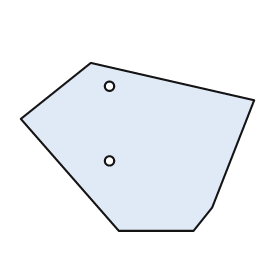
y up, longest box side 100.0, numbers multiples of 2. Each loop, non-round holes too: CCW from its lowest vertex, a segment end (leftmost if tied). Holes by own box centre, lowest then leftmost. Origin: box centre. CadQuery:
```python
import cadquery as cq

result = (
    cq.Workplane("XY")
    .moveTo(-8.0, -36.0)
    .lineTo(24.0, -36.0)
    .lineTo(32.0, -26.0)
    .lineTo(50.0, 20.0)
    .lineTo(-20.0, 36.0)
    .lineTo(-50.0, 12.0)
    .close()
    .moveTo(-12.0, -6.0)
    .circle(2.0)
    .moveTo(-12.0, 26.0)
    .circle(2.0)
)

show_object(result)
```